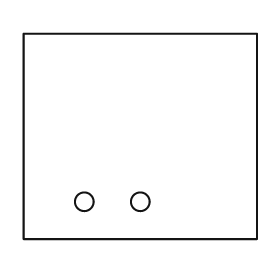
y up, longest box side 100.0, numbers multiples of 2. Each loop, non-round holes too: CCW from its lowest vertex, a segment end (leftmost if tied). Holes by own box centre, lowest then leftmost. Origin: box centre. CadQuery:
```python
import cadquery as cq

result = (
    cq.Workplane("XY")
    .moveTo(-50.0, -44.0)
    .lineTo(50.0, -44.0)
    .lineTo(50.0, 44.0)
    .lineTo(-50.0, 44.0)
    .close()
    .moveTo(-24.0, -28.0)
    .circle(4.0)
    .moveTo(0.0, -28.0)
    .circle(4.0)
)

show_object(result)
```